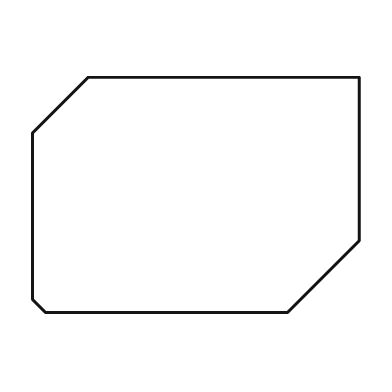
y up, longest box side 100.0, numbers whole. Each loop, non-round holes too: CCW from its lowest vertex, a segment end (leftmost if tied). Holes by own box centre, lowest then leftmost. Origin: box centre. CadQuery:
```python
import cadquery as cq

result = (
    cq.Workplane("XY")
    .moveTo(-46.0, -36.0)
    .lineTo(28.0, -36.0)
    .lineTo(50.0, -14.0)
    .lineTo(50.0, 36.0)
    .lineTo(-33.0, 36.0)
    .lineTo(-50.0, 19.0)
    .lineTo(-50.0, -32.0)
    .close()
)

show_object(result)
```